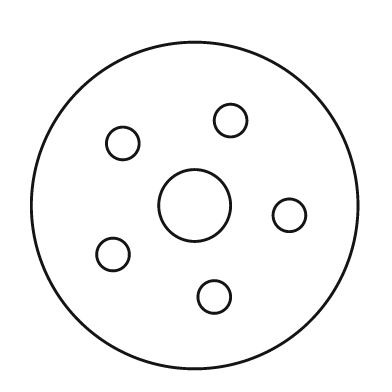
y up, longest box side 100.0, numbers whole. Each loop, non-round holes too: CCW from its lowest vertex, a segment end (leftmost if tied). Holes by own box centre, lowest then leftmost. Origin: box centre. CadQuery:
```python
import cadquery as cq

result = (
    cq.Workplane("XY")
    .moveTo(0.0, 0.0)
    .circle(50.0)
    .moveTo(6.0, -28.0)
    .circle(5.0)
    .moveTo(-25.0, -15.0)
    .circle(5.0)
    .moveTo(29.0, -3.0)
    .circle(5.0)
    .moveTo(0.0, 0.0)
    .circle(11.0)
    .moveTo(-22.0, 19.0)
    .circle(5.0)
    .moveTo(11.0, 26.0)
    .circle(5.0)
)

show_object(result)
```